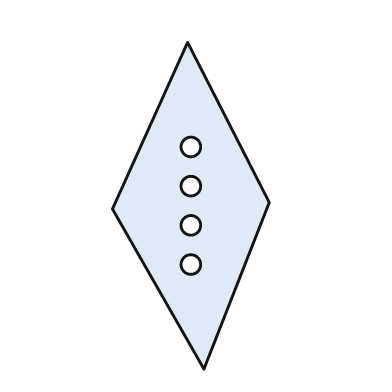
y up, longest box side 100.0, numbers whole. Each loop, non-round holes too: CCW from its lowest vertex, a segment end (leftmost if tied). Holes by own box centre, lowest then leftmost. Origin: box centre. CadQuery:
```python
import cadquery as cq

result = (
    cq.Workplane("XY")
    .moveTo(4.0, -50.0)
    .lineTo(24.0, 1.0)
    .lineTo(-1.0, 50.0)
    .lineTo(-24.0, -1.0)
    .close()
    .moveTo(0.0, -18.0)
    .circle(3.0)
    .moveTo(0.0, -6.0)
    .circle(3.0)
    .moveTo(0.0, 6.0)
    .circle(3.0)
    .moveTo(0.0, 18.0)
    .circle(3.0)
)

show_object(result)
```